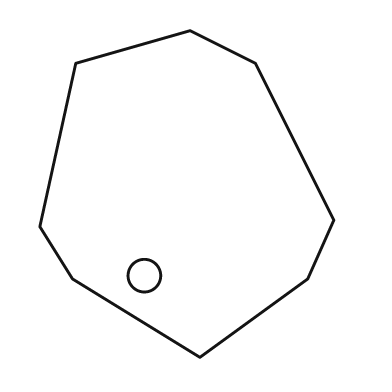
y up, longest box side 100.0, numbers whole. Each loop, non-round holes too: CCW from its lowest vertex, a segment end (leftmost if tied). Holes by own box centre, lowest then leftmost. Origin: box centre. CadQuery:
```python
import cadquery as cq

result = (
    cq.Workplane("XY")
    .moveTo(4.0, -50.0)
    .lineTo(37.0, -26.0)
    .lineTo(45.0, -8.0)
    .lineTo(21.0, 40.0)
    .lineTo(1.0, 50.0)
    .lineTo(-34.0, 40.0)
    .lineTo(-45.0, -10.0)
    .lineTo(-35.0, -26.0)
    .close()
    .moveTo(-13.0, -25.0)
    .circle(5.0)
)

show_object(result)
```